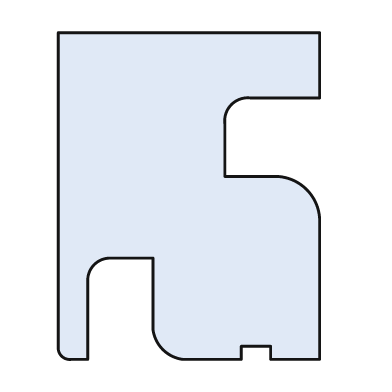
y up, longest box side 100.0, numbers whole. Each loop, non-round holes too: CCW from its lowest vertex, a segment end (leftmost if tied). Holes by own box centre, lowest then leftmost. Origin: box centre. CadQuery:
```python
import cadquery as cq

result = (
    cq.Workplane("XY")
    .moveTo(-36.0, -50.0)
    .lineTo(-31.0, -50.0)
    .lineTo(-31.0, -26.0)
    .threePointArc((-29.0, -21.0), (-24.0, -19.0))
    .lineTo(-11.0, -19.0)
    .lineTo(-11.0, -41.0)
    .threePointArc((-8.0, -47.0), (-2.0, -50.0))
    .lineTo(16.0, -50.0)
    .lineTo(16.0, -46.0)
    .lineTo(25.0, -46.0)
    .lineTo(25.0, -50.0)
    .lineTo(40.0, -50.0)
    .lineTo(40.0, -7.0)
    .threePointArc((36.0, 2.0), (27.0, 6.0))
    .lineTo(11.0, 6.0)
    .lineTo(11.0, 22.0)
    .threePointArc((13.0, 28.0), (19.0, 30.0))
    .lineTo(40.0, 30.0)
    .lineTo(40.0, 50.0)
    .lineTo(-40.0, 50.0)
    .lineTo(-40.0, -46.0)
    .threePointArc((-39.0, -49.0), (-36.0, -50.0))
    .close()
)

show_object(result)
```